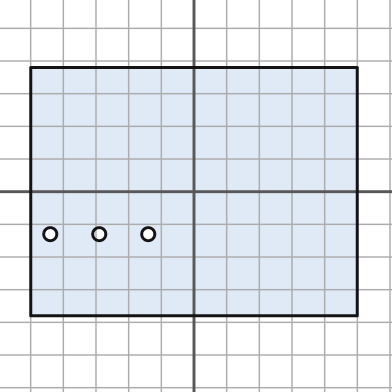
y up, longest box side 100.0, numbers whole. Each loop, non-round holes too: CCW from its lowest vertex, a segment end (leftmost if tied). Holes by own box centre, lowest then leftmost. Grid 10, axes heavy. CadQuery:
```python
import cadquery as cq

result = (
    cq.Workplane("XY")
    .moveTo(-50.0, -38.0)
    .lineTo(50.0, -38.0)
    .lineTo(50.0, 38.0)
    .lineTo(-50.0, 38.0)
    .close()
    .moveTo(-44.0, -13.0)
    .circle(2.0)
    .moveTo(-29.0, -13.0)
    .circle(2.0)
    .moveTo(-14.0, -13.0)
    .circle(2.0)
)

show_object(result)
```